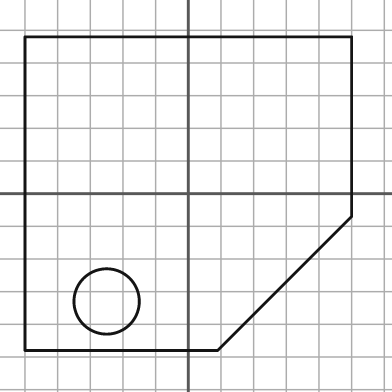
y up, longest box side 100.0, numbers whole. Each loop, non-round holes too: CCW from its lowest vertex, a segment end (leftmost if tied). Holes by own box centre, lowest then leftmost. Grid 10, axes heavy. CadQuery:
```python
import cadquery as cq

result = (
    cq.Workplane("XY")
    .moveTo(-50.0, -48.0)
    .lineTo(9.0, -48.0)
    .lineTo(50.0, -7.0)
    .lineTo(50.0, 48.0)
    .lineTo(-50.0, 48.0)
    .close()
    .moveTo(-25.0, -33.0)
    .circle(10.0)
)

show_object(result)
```